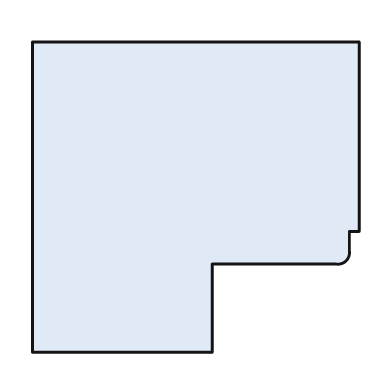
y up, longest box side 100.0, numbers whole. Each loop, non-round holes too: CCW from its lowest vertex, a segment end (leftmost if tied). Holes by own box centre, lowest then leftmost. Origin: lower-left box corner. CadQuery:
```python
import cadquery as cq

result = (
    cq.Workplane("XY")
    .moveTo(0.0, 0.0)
    .lineTo(55.0, 0.0)
    .lineTo(55.0, 27.0)
    .lineTo(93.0, 27.0)
    .threePointArc((96.0, 28.0), (97.0, 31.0))
    .lineTo(97.0, 37.0)
    .lineTo(100.0, 37.0)
    .lineTo(100.0, 95.0)
    .lineTo(0.0, 95.0)
    .close()
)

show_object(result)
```